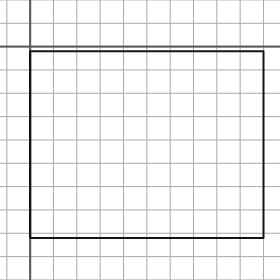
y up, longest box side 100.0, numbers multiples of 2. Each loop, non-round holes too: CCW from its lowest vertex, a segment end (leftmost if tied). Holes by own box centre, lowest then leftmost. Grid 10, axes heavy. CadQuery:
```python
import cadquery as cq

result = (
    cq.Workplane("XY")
    .moveTo(0.0, -82.0)
    .lineTo(100.0, -82.0)
    .lineTo(100.0, -2.0)
    .lineTo(0.0, -2.0)
    .close()
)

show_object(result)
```